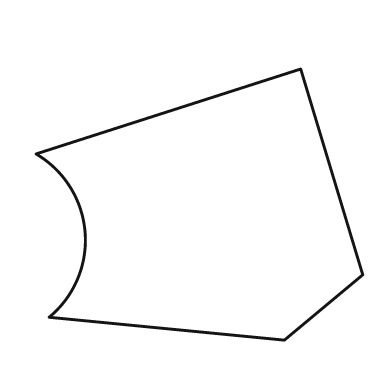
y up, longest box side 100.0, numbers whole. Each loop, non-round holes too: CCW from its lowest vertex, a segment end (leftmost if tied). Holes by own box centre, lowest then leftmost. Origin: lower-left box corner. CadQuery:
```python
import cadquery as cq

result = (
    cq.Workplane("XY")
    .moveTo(76.0, 0.0)
    .lineTo(100.0, 20.0)
    .lineTo(81.0, 83.0)
    .lineTo(0.0, 57.0)
    .threePointArc((15.0, 33.0), (4.0, 7.0))
    .close()
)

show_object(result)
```